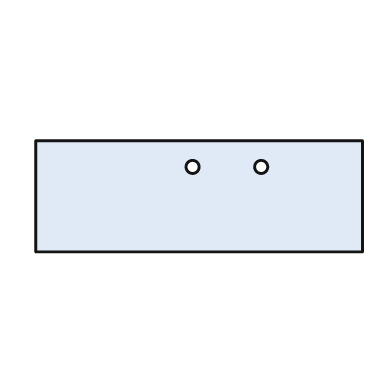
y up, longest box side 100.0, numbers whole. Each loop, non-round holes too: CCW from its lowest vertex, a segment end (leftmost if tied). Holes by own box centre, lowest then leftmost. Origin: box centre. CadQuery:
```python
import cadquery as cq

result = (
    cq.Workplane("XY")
    .moveTo(-50.0, -17.0)
    .lineTo(50.0, -17.0)
    .lineTo(50.0, 17.0)
    .lineTo(-50.0, 17.0)
    .close()
    .moveTo(-2.0, 9.0)
    .circle(2.0)
    .moveTo(19.0, 9.0)
    .circle(2.0)
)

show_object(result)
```